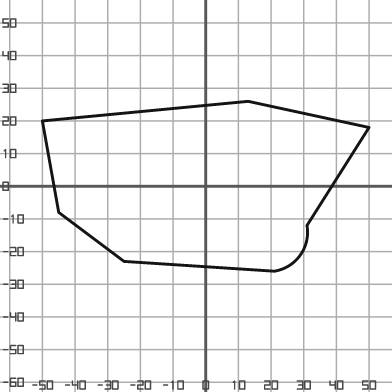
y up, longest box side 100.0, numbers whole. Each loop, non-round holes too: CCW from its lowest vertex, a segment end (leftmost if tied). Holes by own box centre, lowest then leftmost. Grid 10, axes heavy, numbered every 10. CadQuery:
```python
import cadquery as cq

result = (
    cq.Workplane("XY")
    .moveTo(21.0, -26.0)
    .threePointArc((29.0, -21.0), (31.0, -12.0))
    .lineTo(50.0, 18.0)
    .lineTo(13.0, 26.0)
    .lineTo(-50.0, 20.0)
    .lineTo(-45.0, -8.0)
    .lineTo(-25.0, -23.0)
    .close()
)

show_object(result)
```